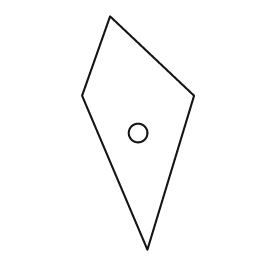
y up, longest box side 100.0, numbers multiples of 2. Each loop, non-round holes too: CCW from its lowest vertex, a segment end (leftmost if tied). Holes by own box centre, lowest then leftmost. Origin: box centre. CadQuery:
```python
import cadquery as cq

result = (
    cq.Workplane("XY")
    .moveTo(4.0, -50.0)
    .lineTo(24.0, 16.0)
    .lineTo(-12.0, 50.0)
    .lineTo(-24.0, 16.0)
    .close()
    .moveTo(0.0, 0.0)
    .circle(4.0)
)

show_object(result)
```